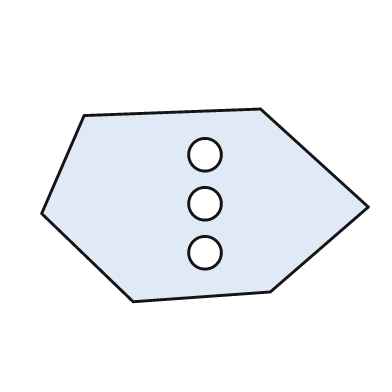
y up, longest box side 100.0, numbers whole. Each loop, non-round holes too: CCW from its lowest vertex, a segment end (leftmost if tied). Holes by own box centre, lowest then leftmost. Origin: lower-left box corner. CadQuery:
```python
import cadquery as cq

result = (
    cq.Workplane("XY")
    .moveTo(28.0, 0.0)
    .lineTo(70.0, 3.0)
    .lineTo(100.0, 29.0)
    .lineTo(67.0, 59.0)
    .lineTo(13.0, 57.0)
    .lineTo(0.0, 27.0)
    .close()
    .moveTo(50.0, 15.0)
    .circle(5.0)
    .moveTo(50.0, 30.0)
    .circle(5.0)
    .moveTo(50.0, 45.0)
    .circle(5.0)
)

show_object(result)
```